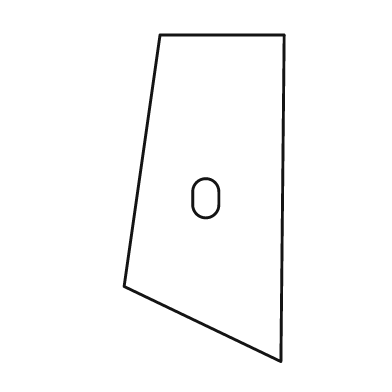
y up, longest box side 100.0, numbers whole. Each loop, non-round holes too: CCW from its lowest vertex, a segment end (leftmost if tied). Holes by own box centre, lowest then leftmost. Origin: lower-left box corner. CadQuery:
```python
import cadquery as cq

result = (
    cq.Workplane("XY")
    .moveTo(48.0, 0.0)
    .lineTo(49.0, 100.0)
    .lineTo(11.0, 100.0)
    .lineTo(0.0, 23.0)
    .close()
    .moveTo(21.0, 48.0)
    .threePointArc((25.0, 44.0), (29.0, 48.0))
    .lineTo(29.0, 52.0)
    .threePointArc((25.0, 56.0), (21.0, 52.0))
    .close()
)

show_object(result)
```